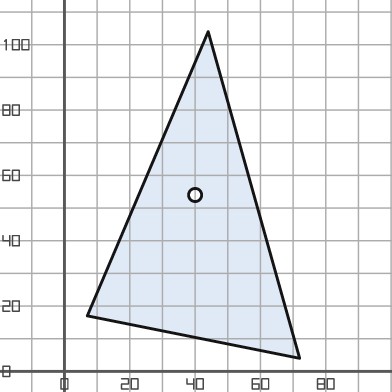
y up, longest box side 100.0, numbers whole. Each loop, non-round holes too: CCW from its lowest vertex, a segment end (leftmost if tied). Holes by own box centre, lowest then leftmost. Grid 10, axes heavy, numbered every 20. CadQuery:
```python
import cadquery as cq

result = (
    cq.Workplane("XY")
    .moveTo(72.0, 4.0)
    .lineTo(44.0, 104.0)
    .lineTo(7.0, 17.0)
    .close()
    .moveTo(40.0, 54.0)
    .circle(2.0)
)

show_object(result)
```